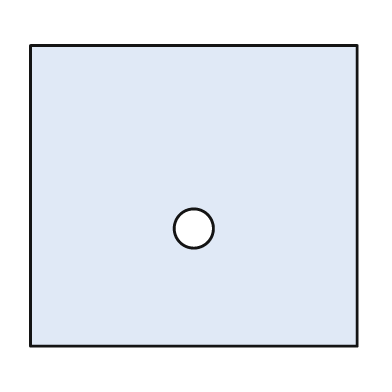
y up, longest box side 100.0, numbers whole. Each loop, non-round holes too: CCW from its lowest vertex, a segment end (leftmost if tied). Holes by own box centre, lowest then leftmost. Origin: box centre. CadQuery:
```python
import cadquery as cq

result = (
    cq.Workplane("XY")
    .moveTo(-50.0, -46.0)
    .lineTo(50.0, -46.0)
    .lineTo(50.0, 46.0)
    .lineTo(-50.0, 46.0)
    .close()
    .moveTo(0.0, -10.0)
    .circle(6.0)
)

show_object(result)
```